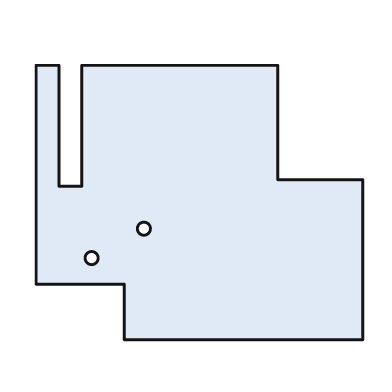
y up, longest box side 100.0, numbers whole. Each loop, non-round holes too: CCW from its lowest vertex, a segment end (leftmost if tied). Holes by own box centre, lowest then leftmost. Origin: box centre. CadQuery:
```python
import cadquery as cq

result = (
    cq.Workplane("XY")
    .moveTo(-23.0, -42.0)
    .lineTo(50.0, -42.0)
    .lineTo(50.0, 7.0)
    .lineTo(24.0, 7.0)
    .lineTo(24.0, 42.0)
    .lineTo(-36.0, 42.0)
    .lineTo(-36.0, 5.0)
    .lineTo(-43.0, 5.0)
    .lineTo(-43.0, 42.0)
    .lineTo(-50.0, 42.0)
    .lineTo(-50.0, -25.0)
    .lineTo(-23.0, -25.0)
    .close()
    .moveTo(-33.0, -17.0)
    .circle(2.0)
    .moveTo(-17.0, -8.0)
    .circle(2.0)
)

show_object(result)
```